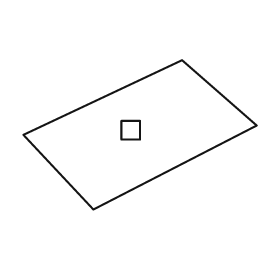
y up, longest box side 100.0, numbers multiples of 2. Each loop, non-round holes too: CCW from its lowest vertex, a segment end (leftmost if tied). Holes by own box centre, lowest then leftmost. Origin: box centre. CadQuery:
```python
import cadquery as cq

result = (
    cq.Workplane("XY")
    .moveTo(-20.0, -32.0)
    .lineTo(50.0, 4.0)
    .lineTo(18.0, 32.0)
    .lineTo(-50.0, 0.0)
    .close()
    .moveTo(-8.0, -2.0)
    .lineTo(0.0, -2.0)
    .lineTo(0.0, 6.0)
    .lineTo(-8.0, 6.0)
    .close()
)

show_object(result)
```